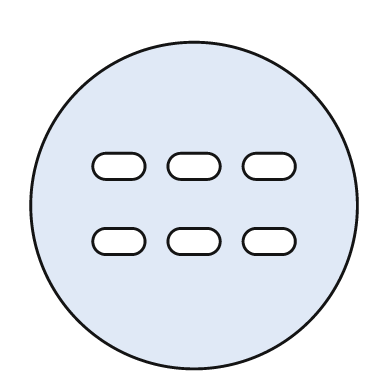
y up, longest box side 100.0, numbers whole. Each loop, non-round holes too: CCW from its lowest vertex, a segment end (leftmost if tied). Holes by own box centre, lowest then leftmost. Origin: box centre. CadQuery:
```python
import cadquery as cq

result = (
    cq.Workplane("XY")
    .moveTo(0.0, 0.0)
    .circle(50.0)
    .moveTo(-27.0, -15.0)
    .lineTo(-19.0, -15.0)
    .threePointArc((-15.0, -11.0), (-19.0, -7.0))
    .lineTo(-27.0, -7.0)
    .threePointArc((-31.0, -11.0), (-27.0, -15.0))
    .close()
    .moveTo(-4.0, -15.0)
    .lineTo(4.0, -15.0)
    .threePointArc((8.0, -11.0), (4.0, -7.0))
    .lineTo(-4.0, -7.0)
    .threePointArc((-8.0, -11.0), (-4.0, -15.0))
    .close()
    .moveTo(19.0, -15.0)
    .lineTo(27.0, -15.0)
    .threePointArc((31.0, -11.0), (27.0, -7.0))
    .lineTo(19.0, -7.0)
    .threePointArc((15.0, -11.0), (19.0, -15.0))
    .close()
    .moveTo(-27.0, 8.0)
    .lineTo(-19.0, 8.0)
    .threePointArc((-15.0, 12.0), (-19.0, 16.0))
    .lineTo(-27.0, 16.0)
    .threePointArc((-31.0, 12.0), (-27.0, 8.0))
    .close()
    .moveTo(-4.0, 8.0)
    .lineTo(4.0, 8.0)
    .threePointArc((8.0, 12.0), (4.0, 16.0))
    .lineTo(-4.0, 16.0)
    .threePointArc((-8.0, 12.0), (-4.0, 8.0))
    .close()
    .moveTo(19.0, 8.0)
    .lineTo(27.0, 8.0)
    .threePointArc((31.0, 12.0), (27.0, 16.0))
    .lineTo(19.0, 16.0)
    .threePointArc((15.0, 12.0), (19.0, 8.0))
    .close()
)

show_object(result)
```